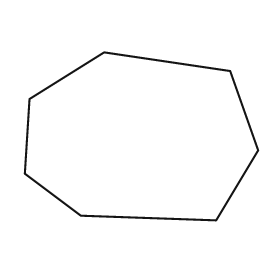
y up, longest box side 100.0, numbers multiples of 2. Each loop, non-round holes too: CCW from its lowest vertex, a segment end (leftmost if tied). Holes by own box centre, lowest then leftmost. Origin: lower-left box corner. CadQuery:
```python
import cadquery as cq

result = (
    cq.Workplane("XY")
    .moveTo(82.0, 0.0)
    .lineTo(100.0, 30.0)
    .lineTo(88.0, 64.0)
    .lineTo(34.0, 72.0)
    .lineTo(2.0, 52.0)
    .lineTo(0.0, 20.0)
    .lineTo(24.0, 2.0)
    .close()
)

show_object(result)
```